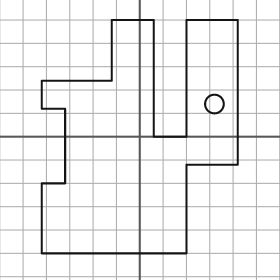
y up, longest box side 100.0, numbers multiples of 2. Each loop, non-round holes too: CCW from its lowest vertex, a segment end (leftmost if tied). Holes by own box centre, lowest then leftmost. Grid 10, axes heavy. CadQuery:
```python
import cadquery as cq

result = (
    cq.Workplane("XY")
    .moveTo(-42.0, -50.0)
    .lineTo(20.0, -50.0)
    .lineTo(20.0, -12.0)
    .lineTo(42.0, -12.0)
    .lineTo(42.0, 50.0)
    .lineTo(20.0, 50.0)
    .lineTo(20.0, 0.0)
    .lineTo(6.0, 0.0)
    .lineTo(6.0, 50.0)
    .lineTo(-12.0, 50.0)
    .lineTo(-12.0, 24.0)
    .lineTo(-42.0, 24.0)
    .lineTo(-42.0, 12.0)
    .lineTo(-32.0, 12.0)
    .lineTo(-32.0, -20.0)
    .lineTo(-42.0, -20.0)
    .close()
    .moveTo(32.0, 14.0)
    .circle(4.0)
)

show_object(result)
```